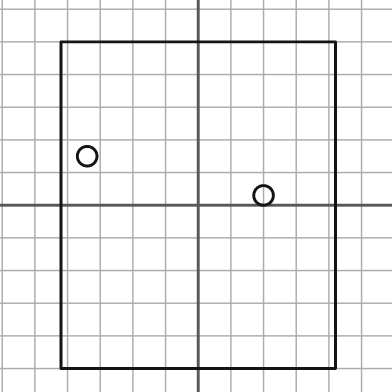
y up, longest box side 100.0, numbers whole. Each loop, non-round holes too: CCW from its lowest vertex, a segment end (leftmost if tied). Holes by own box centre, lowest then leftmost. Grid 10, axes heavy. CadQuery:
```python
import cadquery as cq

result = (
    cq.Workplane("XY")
    .moveTo(-42.0, -50.0)
    .lineTo(42.0, -50.0)
    .lineTo(42.0, 50.0)
    .lineTo(-42.0, 50.0)
    .close()
    .moveTo(20.0, 3.0)
    .circle(3.0)
    .moveTo(-34.0, 15.0)
    .circle(3.0)
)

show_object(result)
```